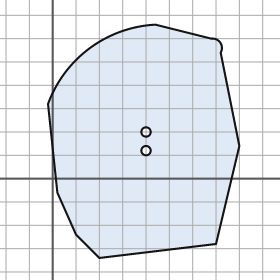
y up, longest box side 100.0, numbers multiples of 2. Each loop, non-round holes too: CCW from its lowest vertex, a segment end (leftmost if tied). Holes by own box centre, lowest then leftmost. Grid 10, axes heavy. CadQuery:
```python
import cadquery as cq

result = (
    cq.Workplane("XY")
    .moveTo(20.0, -34.0)
    .lineTo(70.0, -28.0)
    .lineTo(80.0, 14.0)
    .lineTo(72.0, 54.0)
    .threePointArc((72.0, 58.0), (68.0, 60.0))
    .lineTo(44.0, 66.0)
    .threePointArc((16.0, 56.0), (-2.0, 32.0))
    .lineTo(2.0, -6.0)
    .lineTo(10.0, -24.0)
    .close()
    .moveTo(40.0, 12.0)
    .circle(2.0)
    .moveTo(40.0, 20.0)
    .circle(2.0)
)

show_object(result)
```